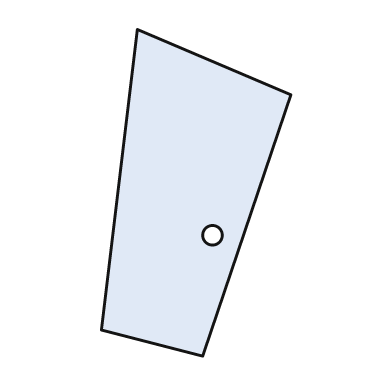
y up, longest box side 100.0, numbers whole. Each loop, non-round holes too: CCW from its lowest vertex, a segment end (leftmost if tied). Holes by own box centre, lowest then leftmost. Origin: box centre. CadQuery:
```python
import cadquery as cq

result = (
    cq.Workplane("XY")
    .moveTo(2.0, -50.0)
    .lineTo(29.0, 30.0)
    .lineTo(-18.0, 50.0)
    .lineTo(-29.0, -42.0)
    .close()
    .moveTo(5.0, -13.0)
    .circle(3.0)
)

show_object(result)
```